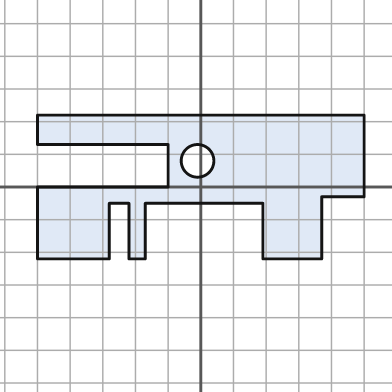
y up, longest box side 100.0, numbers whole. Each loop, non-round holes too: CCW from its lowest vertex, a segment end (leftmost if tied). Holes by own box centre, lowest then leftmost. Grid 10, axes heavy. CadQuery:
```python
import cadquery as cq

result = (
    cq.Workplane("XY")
    .moveTo(-50.0, -22.0)
    .lineTo(-28.0, -22.0)
    .lineTo(-28.0, -5.0)
    .lineTo(-22.0, -5.0)
    .lineTo(-22.0, -22.0)
    .lineTo(-17.0, -22.0)
    .lineTo(-17.0, -5.0)
    .lineTo(19.0, -5.0)
    .lineTo(19.0, -22.0)
    .lineTo(37.0, -22.0)
    .lineTo(37.0, -3.0)
    .lineTo(50.0, -3.0)
    .lineTo(50.0, 22.0)
    .lineTo(-50.0, 22.0)
    .lineTo(-50.0, 13.0)
    .lineTo(-10.0, 13.0)
    .lineTo(-10.0, 0.0)
    .lineTo(-50.0, 0.0)
    .close()
    .moveTo(-1.0, 8.0)
    .circle(5.0)
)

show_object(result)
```